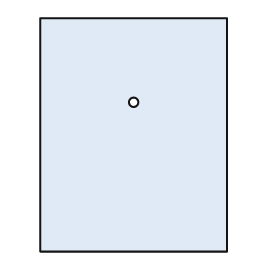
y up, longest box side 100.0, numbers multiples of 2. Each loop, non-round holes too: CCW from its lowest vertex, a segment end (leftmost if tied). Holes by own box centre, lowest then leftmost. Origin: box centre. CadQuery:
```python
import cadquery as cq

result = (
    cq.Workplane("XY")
    .moveTo(-40.0, -50.0)
    .lineTo(40.0, -50.0)
    .lineTo(40.0, 50.0)
    .lineTo(-40.0, 50.0)
    .close()
    .moveTo(0.0, 14.0)
    .circle(2.0)
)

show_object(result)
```